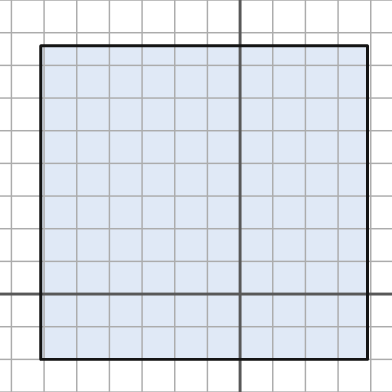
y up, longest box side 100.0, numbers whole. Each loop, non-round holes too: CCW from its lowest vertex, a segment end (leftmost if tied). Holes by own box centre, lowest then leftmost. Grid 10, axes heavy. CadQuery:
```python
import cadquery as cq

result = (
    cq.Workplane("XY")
    .moveTo(-61.0, -20.0)
    .lineTo(39.0, -20.0)
    .lineTo(39.0, 76.0)
    .lineTo(-61.0, 76.0)
    .close()
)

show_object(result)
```